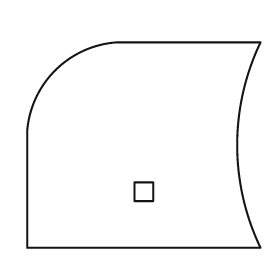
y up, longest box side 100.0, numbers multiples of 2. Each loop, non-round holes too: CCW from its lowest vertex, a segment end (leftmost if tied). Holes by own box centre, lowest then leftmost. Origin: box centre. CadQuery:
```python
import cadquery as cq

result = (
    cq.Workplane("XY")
    .moveTo(-50.0, -44.0)
    .lineTo(50.0, -44.0)
    .threePointArc((40.0, 0.0), (50.0, 44.0))
    .lineTo(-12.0, 44.0)
    .threePointArc((-38.0, 32.0), (-50.0, 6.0))
    .close()
    .moveTo(-4.0, -24.0)
    .lineTo(4.0, -24.0)
    .lineTo(4.0, -16.0)
    .lineTo(-4.0, -16.0)
    .close()
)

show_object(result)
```